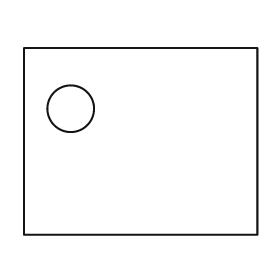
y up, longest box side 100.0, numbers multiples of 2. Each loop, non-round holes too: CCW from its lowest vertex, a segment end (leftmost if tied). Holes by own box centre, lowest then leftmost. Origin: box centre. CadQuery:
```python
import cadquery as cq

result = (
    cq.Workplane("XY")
    .moveTo(-50.0, -40.0)
    .lineTo(50.0, -40.0)
    .lineTo(50.0, 40.0)
    .lineTo(-50.0, 40.0)
    .close()
    .moveTo(-30.0, 14.0)
    .circle(10.0)
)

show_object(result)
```